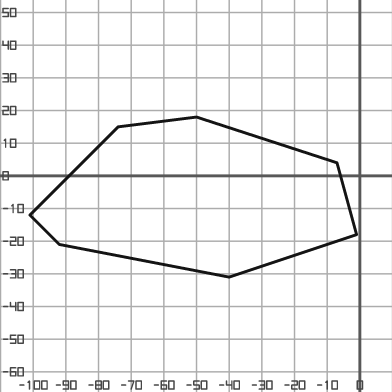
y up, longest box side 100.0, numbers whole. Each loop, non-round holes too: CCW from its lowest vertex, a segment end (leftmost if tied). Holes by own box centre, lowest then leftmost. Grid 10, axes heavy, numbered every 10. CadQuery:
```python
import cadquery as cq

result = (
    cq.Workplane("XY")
    .moveTo(-40.0, -31.0)
    .lineTo(-1.0, -18.0)
    .lineTo(-7.0, 4.0)
    .lineTo(-50.0, 18.0)
    .lineTo(-74.0, 15.0)
    .lineTo(-101.0, -12.0)
    .lineTo(-92.0, -21.0)
    .close()
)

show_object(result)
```